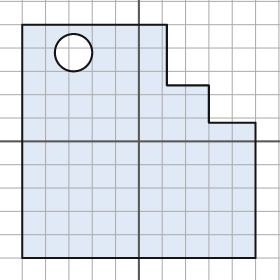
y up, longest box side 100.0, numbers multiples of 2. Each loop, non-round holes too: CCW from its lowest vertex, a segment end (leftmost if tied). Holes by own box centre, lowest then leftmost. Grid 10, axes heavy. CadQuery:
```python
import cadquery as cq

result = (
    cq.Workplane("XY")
    .moveTo(-50.0, -50.0)
    .lineTo(50.0, -50.0)
    .lineTo(50.0, 8.0)
    .lineTo(30.0, 8.0)
    .lineTo(30.0, 24.0)
    .lineTo(12.0, 24.0)
    .lineTo(12.0, 50.0)
    .lineTo(-50.0, 50.0)
    .close()
    .moveTo(-28.0, 38.0)
    .circle(8.0)
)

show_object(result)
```